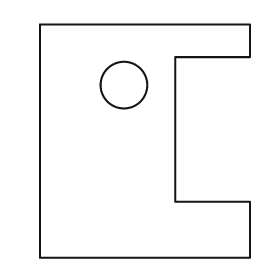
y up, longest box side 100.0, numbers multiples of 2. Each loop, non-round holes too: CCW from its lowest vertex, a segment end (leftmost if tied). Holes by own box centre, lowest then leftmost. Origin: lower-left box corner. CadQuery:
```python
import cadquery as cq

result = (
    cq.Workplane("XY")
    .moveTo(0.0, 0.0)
    .lineTo(90.0, 0.0)
    .lineTo(90.0, 24.0)
    .lineTo(58.0, 24.0)
    .lineTo(58.0, 86.0)
    .lineTo(90.0, 86.0)
    .lineTo(90.0, 100.0)
    .lineTo(0.0, 100.0)
    .close()
    .moveTo(36.0, 74.0)
    .circle(10.0)
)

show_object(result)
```